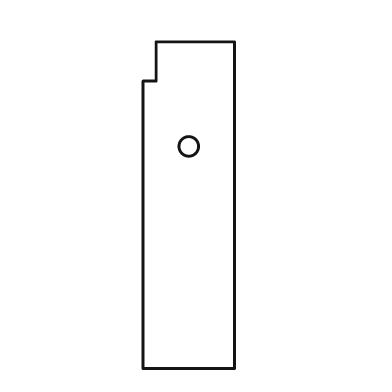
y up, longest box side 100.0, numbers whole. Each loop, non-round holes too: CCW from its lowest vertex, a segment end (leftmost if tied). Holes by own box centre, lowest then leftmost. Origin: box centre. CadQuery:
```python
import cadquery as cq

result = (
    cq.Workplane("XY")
    .moveTo(-14.0, -50.0)
    .lineTo(14.0, -50.0)
    .lineTo(14.0, 50.0)
    .lineTo(-10.0, 50.0)
    .lineTo(-10.0, 38.0)
    .lineTo(-14.0, 38.0)
    .close()
    .moveTo(0.0, 18.0)
    .circle(3.0)
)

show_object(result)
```